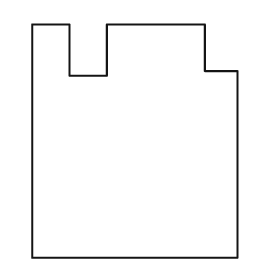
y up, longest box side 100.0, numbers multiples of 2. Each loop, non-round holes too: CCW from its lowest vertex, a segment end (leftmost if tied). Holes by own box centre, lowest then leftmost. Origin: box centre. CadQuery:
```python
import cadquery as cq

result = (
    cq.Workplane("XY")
    .moveTo(-44.0, -50.0)
    .lineTo(44.0, -50.0)
    .lineTo(44.0, 30.0)
    .lineTo(30.0, 30.0)
    .lineTo(30.0, 50.0)
    .lineTo(-12.0, 50.0)
    .lineTo(-12.0, 28.0)
    .lineTo(-28.0, 28.0)
    .lineTo(-28.0, 50.0)
    .lineTo(-44.0, 50.0)
    .close()
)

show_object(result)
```